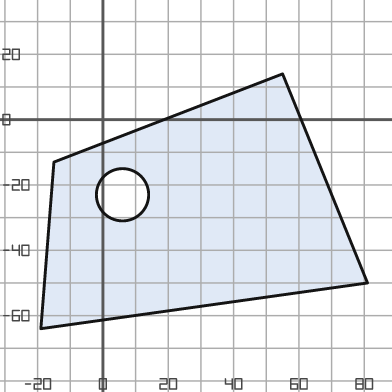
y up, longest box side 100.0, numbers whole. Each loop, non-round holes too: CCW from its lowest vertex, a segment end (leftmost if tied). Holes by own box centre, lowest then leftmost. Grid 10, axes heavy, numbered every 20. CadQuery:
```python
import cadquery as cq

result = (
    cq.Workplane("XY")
    .moveTo(-19.0, -64.0)
    .lineTo(81.0, -50.0)
    .lineTo(55.0, 14.0)
    .lineTo(-15.0, -13.0)
    .close()
    .moveTo(6.0, -23.0)
    .circle(8.0)
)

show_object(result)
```